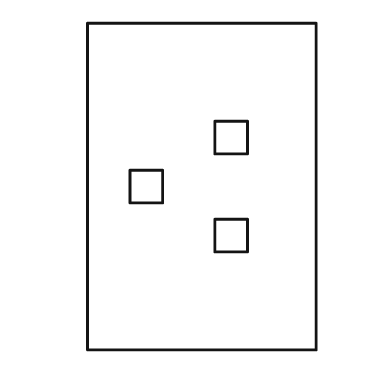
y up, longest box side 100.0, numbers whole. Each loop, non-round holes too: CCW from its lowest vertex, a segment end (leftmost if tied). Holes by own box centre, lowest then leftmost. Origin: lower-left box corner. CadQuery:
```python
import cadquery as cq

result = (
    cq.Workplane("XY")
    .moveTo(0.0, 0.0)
    .lineTo(70.0, 0.0)
    .lineTo(70.0, 100.0)
    .lineTo(0.0, 100.0)
    .close()
    .moveTo(39.0, 30.0)
    .lineTo(49.0, 30.0)
    .lineTo(49.0, 40.0)
    .lineTo(39.0, 40.0)
    .close()
    .moveTo(13.0, 45.0)
    .lineTo(23.0, 45.0)
    .lineTo(23.0, 55.0)
    .lineTo(13.0, 55.0)
    .close()
    .moveTo(39.0, 60.0)
    .lineTo(49.0, 60.0)
    .lineTo(49.0, 70.0)
    .lineTo(39.0, 70.0)
    .close()
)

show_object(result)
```